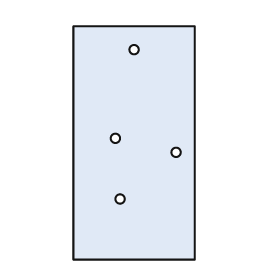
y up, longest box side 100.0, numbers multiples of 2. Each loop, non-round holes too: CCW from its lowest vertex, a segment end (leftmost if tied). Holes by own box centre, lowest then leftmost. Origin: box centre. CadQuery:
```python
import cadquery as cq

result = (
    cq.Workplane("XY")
    .moveTo(-26.0, -50.0)
    .lineTo(26.0, -50.0)
    .lineTo(26.0, 50.0)
    .lineTo(-26.0, 50.0)
    .close()
    .moveTo(-6.0, -24.0)
    .circle(2.0)
    .moveTo(18.0, -4.0)
    .circle(2.0)
    .moveTo(-8.0, 2.0)
    .circle(2.0)
    .moveTo(0.0, 40.0)
    .circle(2.0)
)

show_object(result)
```